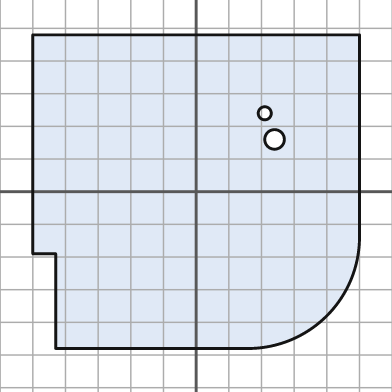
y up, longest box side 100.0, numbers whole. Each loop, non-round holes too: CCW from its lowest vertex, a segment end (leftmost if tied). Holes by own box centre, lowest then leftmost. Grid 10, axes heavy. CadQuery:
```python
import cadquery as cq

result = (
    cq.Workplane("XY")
    .moveTo(-43.0, -48.0)
    .lineTo(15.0, -48.0)
    .threePointArc((40.0, -38.0), (50.0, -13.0))
    .lineTo(50.0, 48.0)
    .lineTo(-50.0, 48.0)
    .lineTo(-50.0, -19.0)
    .lineTo(-43.0, -19.0)
    .close()
    .moveTo(24.0, 16.0)
    .circle(3.0)
    .moveTo(21.0, 24.0)
    .circle(2.0)
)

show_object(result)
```